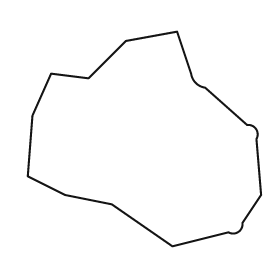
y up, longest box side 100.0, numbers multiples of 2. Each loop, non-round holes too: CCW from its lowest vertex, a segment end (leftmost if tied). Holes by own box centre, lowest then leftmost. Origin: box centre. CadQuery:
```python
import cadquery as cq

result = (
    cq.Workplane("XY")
    .moveTo(12.0, -46.0)
    .lineTo(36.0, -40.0)
    .threePointArc((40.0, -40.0), (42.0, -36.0))
    .lineTo(50.0, -24.0)
    .lineTo(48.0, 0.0)
    .threePointArc((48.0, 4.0), (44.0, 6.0))
    .lineTo(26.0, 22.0)
    .threePointArc((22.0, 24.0), (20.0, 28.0))
    .lineTo(14.0, 46.0)
    .lineTo(-8.0, 42.0)
    .lineTo(-24.0, 26.0)
    .lineTo(-40.0, 28.0)
    .lineTo(-48.0, 10.0)
    .lineTo(-50.0, -16.0)
    .lineTo(-34.0, -24.0)
    .lineTo(-14.0, -28.0)
    .close()
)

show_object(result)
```